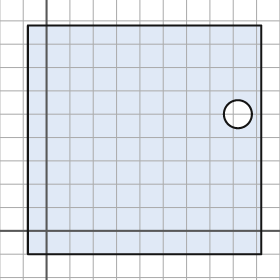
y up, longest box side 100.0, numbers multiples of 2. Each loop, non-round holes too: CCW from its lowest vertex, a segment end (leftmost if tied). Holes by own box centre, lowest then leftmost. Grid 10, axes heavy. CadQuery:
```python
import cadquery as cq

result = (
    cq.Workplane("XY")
    .moveTo(-8.0, -10.0)
    .lineTo(92.0, -10.0)
    .lineTo(92.0, 88.0)
    .lineTo(-8.0, 88.0)
    .close()
    .moveTo(82.0, 50.0)
    .circle(6.0)
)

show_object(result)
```